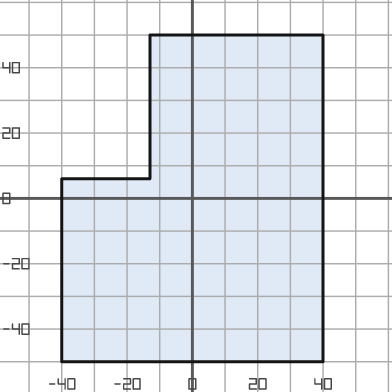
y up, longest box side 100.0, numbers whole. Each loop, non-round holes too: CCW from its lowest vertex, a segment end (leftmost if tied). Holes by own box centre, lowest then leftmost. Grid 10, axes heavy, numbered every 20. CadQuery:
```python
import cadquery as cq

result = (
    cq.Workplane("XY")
    .moveTo(-40.0, -50.0)
    .lineTo(40.0, -50.0)
    .lineTo(40.0, 50.0)
    .lineTo(-13.0, 50.0)
    .lineTo(-13.0, 6.0)
    .lineTo(-40.0, 6.0)
    .close()
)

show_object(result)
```